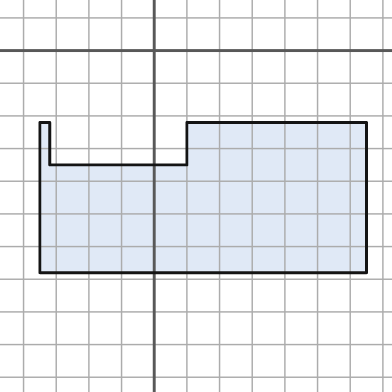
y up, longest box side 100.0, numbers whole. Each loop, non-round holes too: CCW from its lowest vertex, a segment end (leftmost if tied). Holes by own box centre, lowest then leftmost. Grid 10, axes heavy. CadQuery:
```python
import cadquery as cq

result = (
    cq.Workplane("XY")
    .moveTo(-35.0, -68.0)
    .lineTo(65.0, -68.0)
    .lineTo(65.0, -22.0)
    .lineTo(10.0, -22.0)
    .lineTo(10.0, -35.0)
    .lineTo(-32.0, -35.0)
    .lineTo(-32.0, -22.0)
    .lineTo(-35.0, -22.0)
    .close()
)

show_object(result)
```